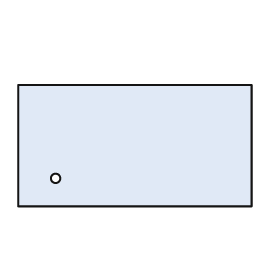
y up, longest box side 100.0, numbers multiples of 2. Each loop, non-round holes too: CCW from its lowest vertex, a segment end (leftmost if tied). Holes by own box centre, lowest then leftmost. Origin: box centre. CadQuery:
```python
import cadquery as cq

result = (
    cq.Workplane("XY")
    .moveTo(-50.0, -26.0)
    .lineTo(50.0, -26.0)
    .lineTo(50.0, 26.0)
    .lineTo(-50.0, 26.0)
    .close()
    .moveTo(-34.0, -14.0)
    .circle(2.0)
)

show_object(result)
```